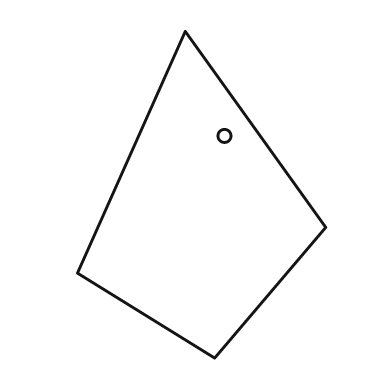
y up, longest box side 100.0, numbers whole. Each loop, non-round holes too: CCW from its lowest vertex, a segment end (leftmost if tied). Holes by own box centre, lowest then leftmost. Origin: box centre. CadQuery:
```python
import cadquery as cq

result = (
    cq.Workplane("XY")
    .moveTo(4.0, -50.0)
    .lineTo(38.0, -10.0)
    .lineTo(-5.0, 50.0)
    .lineTo(-38.0, -24.0)
    .close()
    .moveTo(7.0, 18.0)
    .circle(2.0)
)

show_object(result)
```